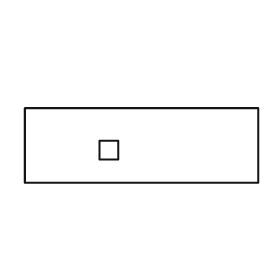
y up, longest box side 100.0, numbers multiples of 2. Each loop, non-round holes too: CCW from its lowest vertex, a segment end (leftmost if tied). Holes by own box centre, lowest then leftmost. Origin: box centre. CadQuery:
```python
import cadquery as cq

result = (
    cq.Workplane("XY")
    .moveTo(-50.0, -16.0)
    .lineTo(50.0, -16.0)
    .lineTo(50.0, 16.0)
    .lineTo(-50.0, 16.0)
    .close()
    .moveTo(-18.0, -6.0)
    .lineTo(-10.0, -6.0)
    .lineTo(-10.0, 2.0)
    .lineTo(-18.0, 2.0)
    .close()
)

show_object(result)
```